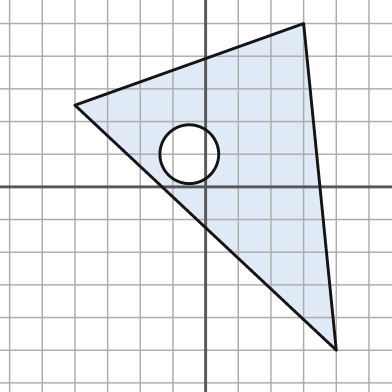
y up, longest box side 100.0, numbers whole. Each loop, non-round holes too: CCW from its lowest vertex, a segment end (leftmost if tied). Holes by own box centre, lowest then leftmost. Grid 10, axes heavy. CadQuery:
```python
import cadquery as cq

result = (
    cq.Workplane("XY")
    .moveTo(40.0, -50.0)
    .lineTo(30.0, 50.0)
    .lineTo(-40.0, 25.0)
    .close()
    .moveTo(-5.0, 10.0)
    .circle(9.0)
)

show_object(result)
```